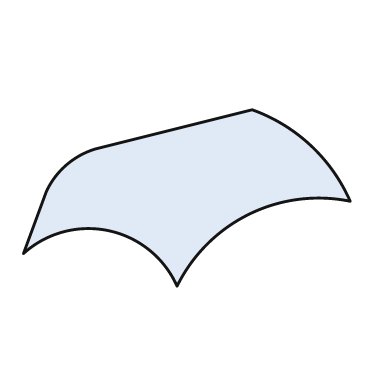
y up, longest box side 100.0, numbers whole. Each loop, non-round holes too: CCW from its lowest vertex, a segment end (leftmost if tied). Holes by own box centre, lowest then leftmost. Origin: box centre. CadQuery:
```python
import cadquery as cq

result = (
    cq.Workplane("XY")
    .moveTo(-3.0, -27.0)
    .threePointArc((19.0, -5.0), (50.0, -1.0))
    .threePointArc((38.0, 16.0), (20.0, 27.0))
    .lineTo(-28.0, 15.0)
    .threePointArc((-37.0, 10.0), (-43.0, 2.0))
    .lineTo(-50.0, -17.0)
    .threePointArc((-24.0, -10.0), (-3.0, -27.0))
    .close()
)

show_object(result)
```